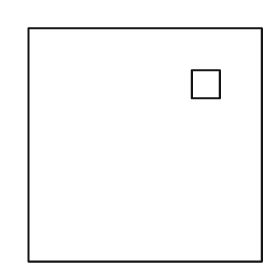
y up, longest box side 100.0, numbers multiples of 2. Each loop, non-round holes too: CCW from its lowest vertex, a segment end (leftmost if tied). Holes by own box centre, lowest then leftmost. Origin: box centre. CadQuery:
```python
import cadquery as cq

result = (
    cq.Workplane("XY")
    .moveTo(-50.0, -50.0)
    .lineTo(50.0, -50.0)
    .lineTo(50.0, 50.0)
    .lineTo(-50.0, 50.0)
    .close()
    .moveTo(20.0, 20.0)
    .lineTo(32.0, 20.0)
    .lineTo(32.0, 32.0)
    .lineTo(20.0, 32.0)
    .close()
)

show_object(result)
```